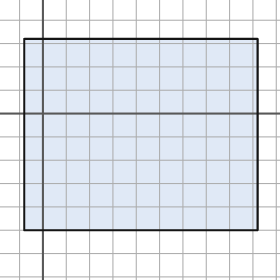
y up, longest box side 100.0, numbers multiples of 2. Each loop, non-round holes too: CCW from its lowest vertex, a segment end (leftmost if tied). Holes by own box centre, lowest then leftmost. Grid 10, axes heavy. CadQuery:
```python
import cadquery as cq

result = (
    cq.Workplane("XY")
    .moveTo(-8.0, -50.0)
    .lineTo(92.0, -50.0)
    .lineTo(92.0, 32.0)
    .lineTo(-8.0, 32.0)
    .close()
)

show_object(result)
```